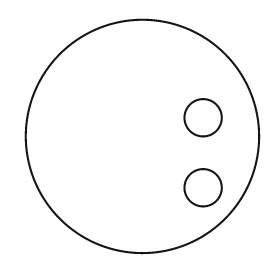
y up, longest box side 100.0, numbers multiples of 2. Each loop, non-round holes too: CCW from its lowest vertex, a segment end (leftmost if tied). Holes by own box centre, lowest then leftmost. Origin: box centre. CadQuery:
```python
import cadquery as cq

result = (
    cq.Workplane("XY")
    .moveTo(0.0, 0.0)
    .circle(50.0)
    .moveTo(26.0, -22.0)
    .circle(8.0)
    .moveTo(26.0, 8.0)
    .circle(8.0)
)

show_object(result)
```